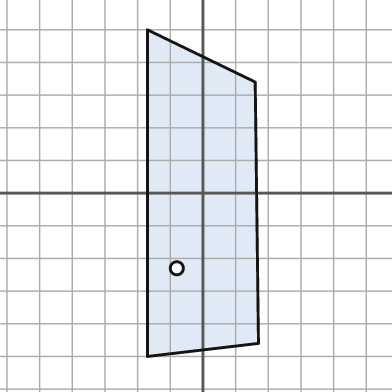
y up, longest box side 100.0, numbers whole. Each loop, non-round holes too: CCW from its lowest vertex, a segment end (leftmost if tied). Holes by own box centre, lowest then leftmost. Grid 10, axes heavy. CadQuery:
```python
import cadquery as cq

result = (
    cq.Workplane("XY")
    .moveTo(-17.0, -50.0)
    .lineTo(17.0, -46.0)
    .lineTo(16.0, 34.0)
    .lineTo(-17.0, 50.0)
    .close()
    .moveTo(-8.0, -23.0)
    .circle(2.0)
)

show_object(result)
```